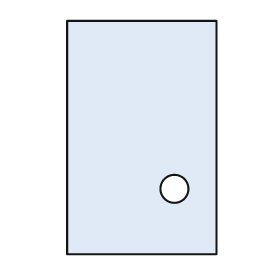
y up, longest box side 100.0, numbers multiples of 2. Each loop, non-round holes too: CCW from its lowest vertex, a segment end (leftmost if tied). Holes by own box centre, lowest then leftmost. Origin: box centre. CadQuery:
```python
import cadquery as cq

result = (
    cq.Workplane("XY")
    .moveTo(-32.0, -50.0)
    .lineTo(32.0, -50.0)
    .lineTo(32.0, 50.0)
    .lineTo(-32.0, 50.0)
    .close()
    .moveTo(14.0, -22.0)
    .circle(6.0)
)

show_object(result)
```